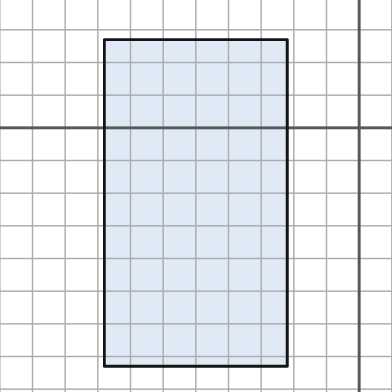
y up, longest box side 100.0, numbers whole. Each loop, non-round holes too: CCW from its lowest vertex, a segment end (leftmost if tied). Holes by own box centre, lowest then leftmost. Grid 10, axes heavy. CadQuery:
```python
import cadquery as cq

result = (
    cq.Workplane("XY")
    .moveTo(-78.0, -73.0)
    .lineTo(-22.0, -73.0)
    .lineTo(-22.0, 27.0)
    .lineTo(-78.0, 27.0)
    .close()
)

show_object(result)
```